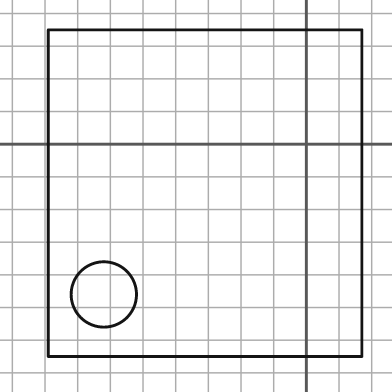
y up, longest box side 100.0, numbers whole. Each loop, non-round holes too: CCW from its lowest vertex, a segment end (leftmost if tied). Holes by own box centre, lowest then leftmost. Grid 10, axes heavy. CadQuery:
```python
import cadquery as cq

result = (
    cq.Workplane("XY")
    .moveTo(-79.0, -65.0)
    .lineTo(17.0, -65.0)
    .lineTo(17.0, 35.0)
    .lineTo(-79.0, 35.0)
    .close()
    .moveTo(-62.0, -46.0)
    .circle(10.0)
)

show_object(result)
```